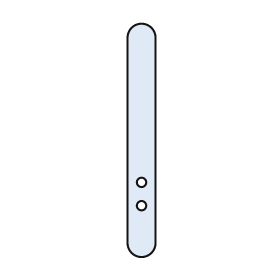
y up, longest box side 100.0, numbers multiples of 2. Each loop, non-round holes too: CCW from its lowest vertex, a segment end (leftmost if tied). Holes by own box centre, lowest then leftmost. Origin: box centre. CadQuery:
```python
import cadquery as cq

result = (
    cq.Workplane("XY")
    .moveTo(-6.0, -44.0)
    .threePointArc((0.0, -50.0), (6.0, -44.0))
    .lineTo(6.0, 44.0)
    .threePointArc((0.0, 50.0), (-6.0, 44.0))
    .close()
    .moveTo(0.0, -28.0)
    .circle(2.0)
    .moveTo(0.0, -18.0)
    .circle(2.0)
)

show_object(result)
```